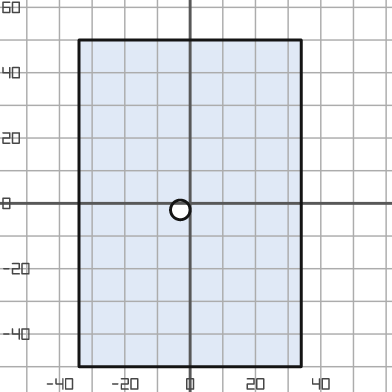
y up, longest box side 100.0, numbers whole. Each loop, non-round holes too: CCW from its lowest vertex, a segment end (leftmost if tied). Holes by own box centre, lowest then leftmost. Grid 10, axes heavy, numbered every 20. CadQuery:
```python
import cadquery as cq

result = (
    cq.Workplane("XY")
    .moveTo(-34.0, -50.0)
    .lineTo(34.0, -50.0)
    .lineTo(34.0, 50.0)
    .lineTo(-34.0, 50.0)
    .close()
    .moveTo(-3.0, -2.0)
    .circle(3.0)
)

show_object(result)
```